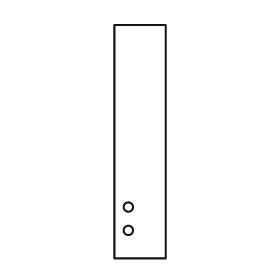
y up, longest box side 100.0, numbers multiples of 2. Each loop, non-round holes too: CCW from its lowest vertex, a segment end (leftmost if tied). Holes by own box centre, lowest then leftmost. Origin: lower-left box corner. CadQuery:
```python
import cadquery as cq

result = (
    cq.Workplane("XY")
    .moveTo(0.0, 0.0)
    .lineTo(22.0, 0.0)
    .lineTo(22.0, 100.0)
    .lineTo(0.0, 100.0)
    .close()
    .moveTo(6.0, 12.0)
    .circle(2.0)
    .moveTo(6.0, 22.0)
    .circle(2.0)
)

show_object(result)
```